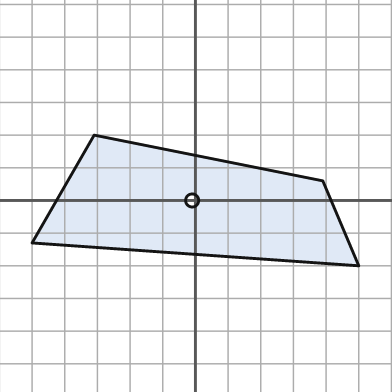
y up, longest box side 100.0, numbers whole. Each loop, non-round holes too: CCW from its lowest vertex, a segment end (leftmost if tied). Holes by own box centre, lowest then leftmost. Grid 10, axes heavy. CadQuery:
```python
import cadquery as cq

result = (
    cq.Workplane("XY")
    .moveTo(50.0, -20.0)
    .lineTo(39.0, 6.0)
    .lineTo(-31.0, 20.0)
    .lineTo(-50.0, -13.0)
    .close()
    .moveTo(-1.0, 0.0)
    .circle(2.0)
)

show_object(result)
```